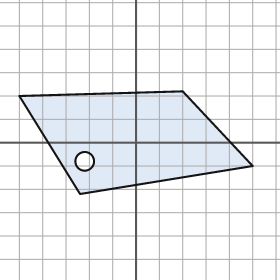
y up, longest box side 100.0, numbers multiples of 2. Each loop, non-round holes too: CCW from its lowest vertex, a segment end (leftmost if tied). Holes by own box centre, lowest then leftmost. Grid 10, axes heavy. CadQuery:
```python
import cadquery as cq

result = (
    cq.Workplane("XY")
    .moveTo(-24.0, -22.0)
    .lineTo(50.0, -10.0)
    .lineTo(20.0, 22.0)
    .lineTo(-50.0, 20.0)
    .close()
    .moveTo(-22.0, -8.0)
    .circle(4.0)
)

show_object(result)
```